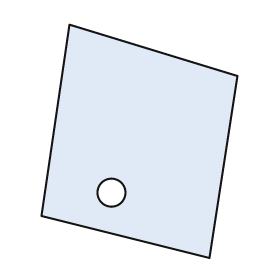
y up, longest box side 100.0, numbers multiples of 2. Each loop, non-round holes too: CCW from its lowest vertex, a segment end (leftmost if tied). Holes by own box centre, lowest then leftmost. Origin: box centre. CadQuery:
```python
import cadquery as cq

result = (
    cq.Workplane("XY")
    .moveTo(30.0, -50.0)
    .lineTo(42.0, 28.0)
    .lineTo(-30.0, 50.0)
    .lineTo(-42.0, -32.0)
    .close()
    .moveTo(-12.0, -22.0)
    .circle(6.0)
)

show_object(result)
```